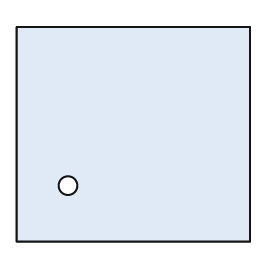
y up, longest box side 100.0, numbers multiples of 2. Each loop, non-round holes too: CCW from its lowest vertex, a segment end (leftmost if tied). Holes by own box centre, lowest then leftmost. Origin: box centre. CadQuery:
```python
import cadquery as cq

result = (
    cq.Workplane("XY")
    .moveTo(-50.0, -46.0)
    .lineTo(50.0, -46.0)
    .lineTo(50.0, 46.0)
    .lineTo(-50.0, 46.0)
    .close()
    .moveTo(-28.0, -22.0)
    .circle(4.0)
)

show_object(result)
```